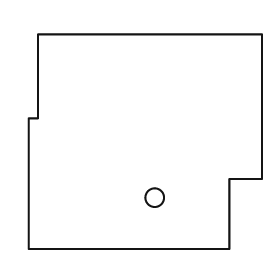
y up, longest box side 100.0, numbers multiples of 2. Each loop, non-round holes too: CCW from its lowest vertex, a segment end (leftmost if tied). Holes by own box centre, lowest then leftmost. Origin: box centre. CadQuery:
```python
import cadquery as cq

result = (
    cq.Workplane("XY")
    .moveTo(-50.0, -46.0)
    .lineTo(36.0, -46.0)
    .lineTo(36.0, -16.0)
    .lineTo(50.0, -16.0)
    .lineTo(50.0, 46.0)
    .lineTo(-46.0, 46.0)
    .lineTo(-46.0, 10.0)
    .lineTo(-50.0, 10.0)
    .close()
    .moveTo(4.0, -24.0)
    .circle(4.0)
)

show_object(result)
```